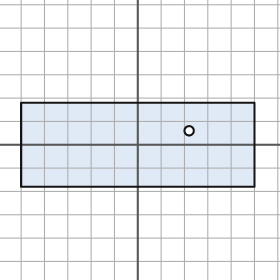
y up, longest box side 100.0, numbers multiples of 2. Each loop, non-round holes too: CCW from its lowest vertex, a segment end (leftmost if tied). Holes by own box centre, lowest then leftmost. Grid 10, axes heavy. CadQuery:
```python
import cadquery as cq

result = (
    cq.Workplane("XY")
    .moveTo(-50.0, -18.0)
    .lineTo(50.0, -18.0)
    .lineTo(50.0, 18.0)
    .lineTo(-50.0, 18.0)
    .close()
    .moveTo(22.0, 6.0)
    .circle(2.0)
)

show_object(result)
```